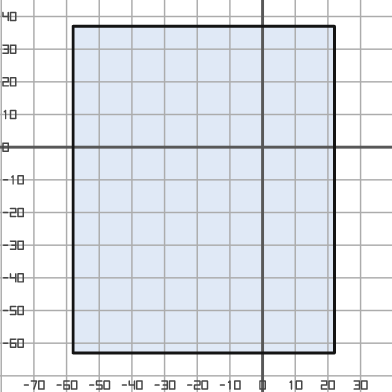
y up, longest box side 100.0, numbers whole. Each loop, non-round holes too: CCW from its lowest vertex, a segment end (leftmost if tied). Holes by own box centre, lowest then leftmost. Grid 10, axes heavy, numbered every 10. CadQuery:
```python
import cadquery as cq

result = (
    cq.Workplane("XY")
    .moveTo(-58.0, -63.0)
    .lineTo(22.0, -63.0)
    .lineTo(22.0, 37.0)
    .lineTo(-58.0, 37.0)
    .close()
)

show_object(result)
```